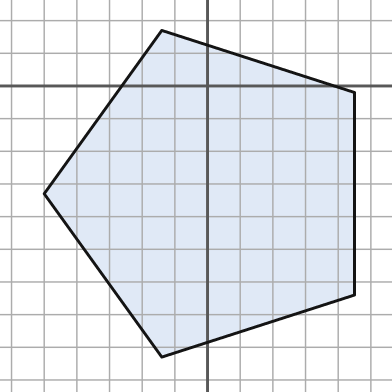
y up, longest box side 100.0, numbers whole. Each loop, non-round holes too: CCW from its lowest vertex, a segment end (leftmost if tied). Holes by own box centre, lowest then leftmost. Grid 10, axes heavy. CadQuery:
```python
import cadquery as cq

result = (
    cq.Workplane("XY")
    .moveTo(-14.0, -83.0)
    .lineTo(45.0, -64.0)
    .lineTo(45.0, -2.0)
    .lineTo(-14.0, 17.0)
    .lineTo(-50.0, -33.0)
    .close()
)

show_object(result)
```